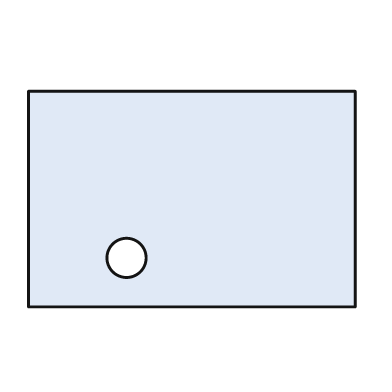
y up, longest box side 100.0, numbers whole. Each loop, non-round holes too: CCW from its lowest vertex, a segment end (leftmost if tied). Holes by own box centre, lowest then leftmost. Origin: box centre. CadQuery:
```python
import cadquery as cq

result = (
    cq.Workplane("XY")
    .moveTo(-50.0, -33.0)
    .lineTo(50.0, -33.0)
    .lineTo(50.0, 33.0)
    .lineTo(-50.0, 33.0)
    .close()
    .moveTo(-20.0, -18.0)
    .circle(6.0)
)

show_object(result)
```